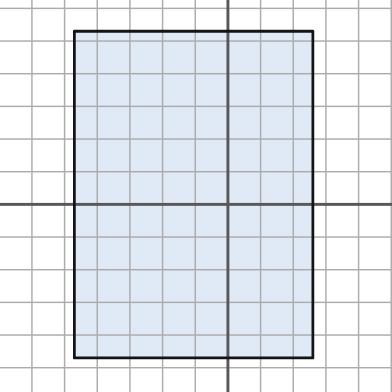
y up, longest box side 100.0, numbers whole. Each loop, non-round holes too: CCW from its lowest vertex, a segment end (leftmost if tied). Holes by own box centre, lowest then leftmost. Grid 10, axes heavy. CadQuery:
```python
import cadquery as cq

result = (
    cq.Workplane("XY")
    .moveTo(-47.0, -47.0)
    .lineTo(26.0, -47.0)
    .lineTo(26.0, 53.0)
    .lineTo(-47.0, 53.0)
    .close()
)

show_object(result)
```